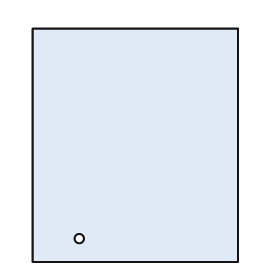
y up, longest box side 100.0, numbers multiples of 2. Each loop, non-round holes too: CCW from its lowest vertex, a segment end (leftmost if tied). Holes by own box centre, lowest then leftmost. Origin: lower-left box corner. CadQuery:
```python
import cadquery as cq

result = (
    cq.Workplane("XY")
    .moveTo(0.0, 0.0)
    .lineTo(88.0, 0.0)
    .lineTo(88.0, 100.0)
    .lineTo(0.0, 100.0)
    .close()
    .moveTo(20.0, 10.0)
    .circle(2.0)
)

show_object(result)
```